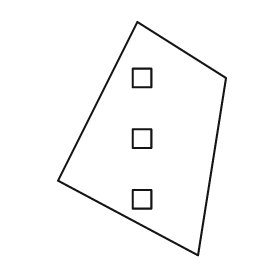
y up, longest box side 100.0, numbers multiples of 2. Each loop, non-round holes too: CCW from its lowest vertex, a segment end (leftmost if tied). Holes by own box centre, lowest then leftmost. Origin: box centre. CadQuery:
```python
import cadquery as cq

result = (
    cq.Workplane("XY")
    .moveTo(24.0, -50.0)
    .lineTo(36.0, 26.0)
    .lineTo(-2.0, 50.0)
    .lineTo(-36.0, -18.0)
    .close()
    .moveTo(-4.0, -30.0)
    .lineTo(4.0, -30.0)
    .lineTo(4.0, -22.0)
    .lineTo(-4.0, -22.0)
    .close()
    .moveTo(-4.0, -4.0)
    .lineTo(4.0, -4.0)
    .lineTo(4.0, 4.0)
    .lineTo(-4.0, 4.0)
    .close()
    .moveTo(-4.0, 22.0)
    .lineTo(4.0, 22.0)
    .lineTo(4.0, 30.0)
    .lineTo(-4.0, 30.0)
    .close()
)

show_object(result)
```